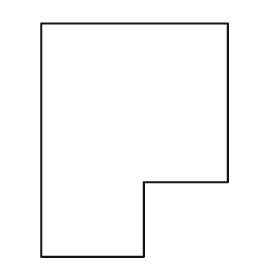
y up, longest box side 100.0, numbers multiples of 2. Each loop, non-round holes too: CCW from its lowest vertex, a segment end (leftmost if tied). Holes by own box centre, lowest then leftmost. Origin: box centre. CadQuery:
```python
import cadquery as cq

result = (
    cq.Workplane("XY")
    .moveTo(-40.0, -50.0)
    .lineTo(4.0, -50.0)
    .lineTo(4.0, -18.0)
    .lineTo(40.0, -18.0)
    .lineTo(40.0, 50.0)
    .lineTo(-40.0, 50.0)
    .close()
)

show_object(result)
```